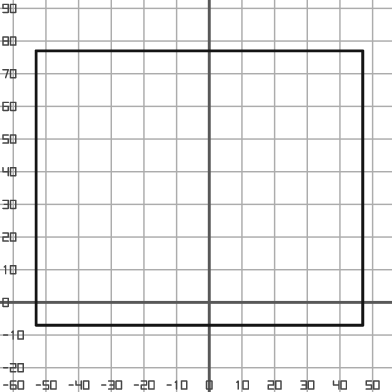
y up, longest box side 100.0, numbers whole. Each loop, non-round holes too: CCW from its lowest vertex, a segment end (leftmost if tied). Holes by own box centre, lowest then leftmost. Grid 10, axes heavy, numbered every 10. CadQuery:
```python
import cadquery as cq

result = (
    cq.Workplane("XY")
    .moveTo(-53.0, -7.0)
    .lineTo(47.0, -7.0)
    .lineTo(47.0, 77.0)
    .lineTo(-53.0, 77.0)
    .close()
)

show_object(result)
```